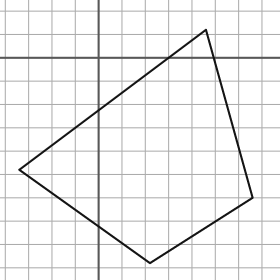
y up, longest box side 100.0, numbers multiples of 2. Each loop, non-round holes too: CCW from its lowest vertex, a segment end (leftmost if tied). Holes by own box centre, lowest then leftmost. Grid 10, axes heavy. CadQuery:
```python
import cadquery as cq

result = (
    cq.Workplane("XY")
    .moveTo(22.0, -88.0)
    .lineTo(66.0, -60.0)
    .lineTo(46.0, 12.0)
    .lineTo(-34.0, -48.0)
    .close()
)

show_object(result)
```